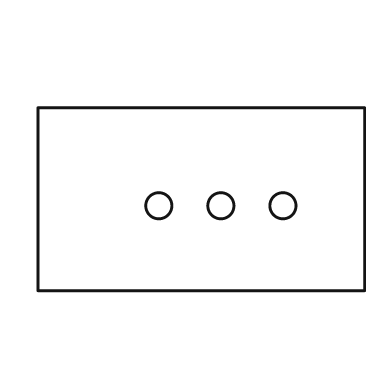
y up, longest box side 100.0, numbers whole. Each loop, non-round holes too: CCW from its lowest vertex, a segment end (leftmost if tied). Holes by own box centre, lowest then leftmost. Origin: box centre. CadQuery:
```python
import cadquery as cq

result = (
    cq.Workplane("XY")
    .moveTo(-50.0, -28.0)
    .lineTo(50.0, -28.0)
    .lineTo(50.0, 28.0)
    .lineTo(-50.0, 28.0)
    .close()
    .moveTo(-13.0, -2.0)
    .circle(4.0)
    .moveTo(6.0, -2.0)
    .circle(4.0)
    .moveTo(25.0, -2.0)
    .circle(4.0)
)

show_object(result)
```